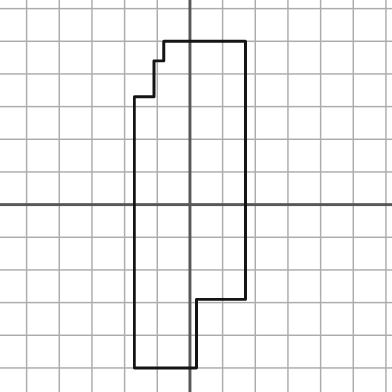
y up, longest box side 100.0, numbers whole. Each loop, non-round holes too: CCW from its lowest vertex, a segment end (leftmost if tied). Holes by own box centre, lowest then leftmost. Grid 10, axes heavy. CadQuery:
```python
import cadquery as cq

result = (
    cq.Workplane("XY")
    .moveTo(-17.0, -50.0)
    .lineTo(2.0, -50.0)
    .lineTo(2.0, -29.0)
    .lineTo(17.0, -29.0)
    .lineTo(17.0, 50.0)
    .lineTo(-8.0, 50.0)
    .lineTo(-8.0, 44.0)
    .lineTo(-11.0, 44.0)
    .lineTo(-11.0, 33.0)
    .lineTo(-17.0, 33.0)
    .close()
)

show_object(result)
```